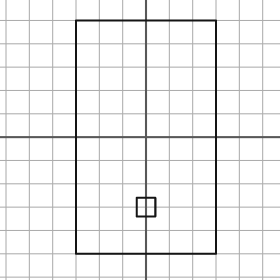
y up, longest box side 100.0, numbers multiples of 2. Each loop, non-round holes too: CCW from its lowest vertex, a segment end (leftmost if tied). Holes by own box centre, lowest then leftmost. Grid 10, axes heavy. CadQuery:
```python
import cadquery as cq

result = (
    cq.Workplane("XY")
    .moveTo(-30.0, -50.0)
    .lineTo(30.0, -50.0)
    .lineTo(30.0, 50.0)
    .lineTo(-30.0, 50.0)
    .close()
    .moveTo(-4.0, -34.0)
    .lineTo(4.0, -34.0)
    .lineTo(4.0, -26.0)
    .lineTo(-4.0, -26.0)
    .close()
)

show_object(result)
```